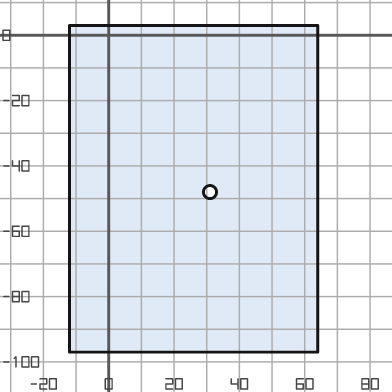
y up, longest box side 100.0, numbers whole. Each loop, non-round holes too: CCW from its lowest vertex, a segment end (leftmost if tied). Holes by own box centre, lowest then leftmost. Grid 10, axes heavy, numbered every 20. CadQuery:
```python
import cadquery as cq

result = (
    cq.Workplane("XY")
    .moveTo(-12.0, -97.0)
    .lineTo(64.0, -97.0)
    .lineTo(64.0, 3.0)
    .lineTo(-12.0, 3.0)
    .close()
    .moveTo(31.0, -48.0)
    .circle(2.0)
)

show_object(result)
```